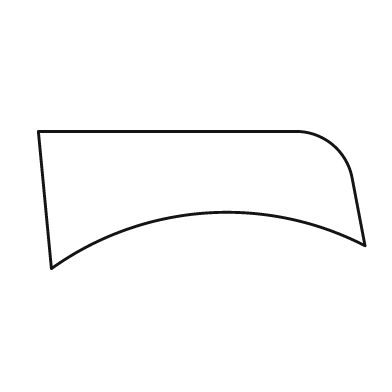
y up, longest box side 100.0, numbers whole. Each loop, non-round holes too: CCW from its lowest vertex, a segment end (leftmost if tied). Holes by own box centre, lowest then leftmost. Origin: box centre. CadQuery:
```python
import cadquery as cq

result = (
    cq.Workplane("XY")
    .moveTo(-46.0, -21.0)
    .threePointArc((1.0, -4.0), (50.0, -14.0))
    .lineTo(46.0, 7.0)
    .threePointArc((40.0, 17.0), (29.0, 21.0))
    .lineTo(-50.0, 21.0)
    .close()
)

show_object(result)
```